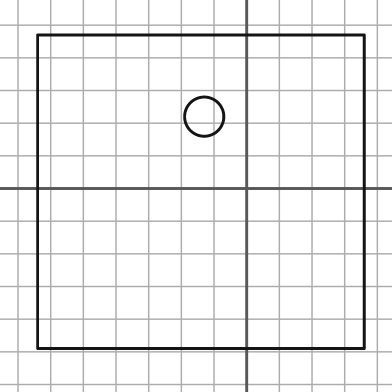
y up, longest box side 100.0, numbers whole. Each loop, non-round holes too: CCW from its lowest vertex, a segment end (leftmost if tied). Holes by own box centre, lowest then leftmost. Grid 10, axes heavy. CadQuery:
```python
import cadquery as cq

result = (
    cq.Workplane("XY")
    .moveTo(-64.0, -49.0)
    .lineTo(36.0, -49.0)
    .lineTo(36.0, 47.0)
    .lineTo(-64.0, 47.0)
    .close()
    .moveTo(-13.0, 22.0)
    .circle(6.0)
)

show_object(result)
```